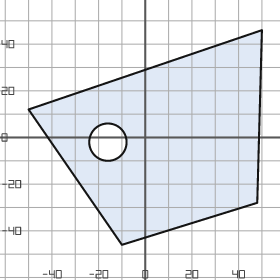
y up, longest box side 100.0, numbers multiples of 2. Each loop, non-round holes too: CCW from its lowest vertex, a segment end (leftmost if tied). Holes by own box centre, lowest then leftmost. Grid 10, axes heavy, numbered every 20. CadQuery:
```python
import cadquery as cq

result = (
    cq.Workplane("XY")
    .moveTo(-10.0, -46.0)
    .lineTo(48.0, -28.0)
    .lineTo(50.0, 46.0)
    .lineTo(-50.0, 12.0)
    .close()
    .moveTo(-16.0, -2.0)
    .circle(8.0)
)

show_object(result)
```